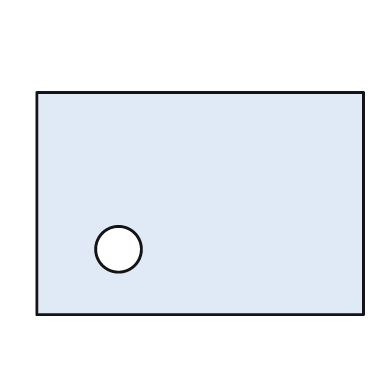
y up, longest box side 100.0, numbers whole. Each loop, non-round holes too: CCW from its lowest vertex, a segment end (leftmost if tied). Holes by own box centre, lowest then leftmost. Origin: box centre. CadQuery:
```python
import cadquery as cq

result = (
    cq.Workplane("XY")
    .moveTo(-50.0, -34.0)
    .lineTo(50.0, -34.0)
    .lineTo(50.0, 34.0)
    .lineTo(-50.0, 34.0)
    .close()
    .moveTo(-25.0, -14.0)
    .circle(7.0)
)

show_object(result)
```